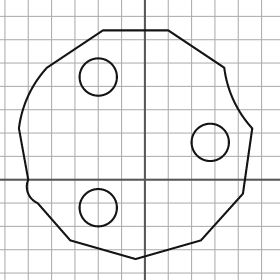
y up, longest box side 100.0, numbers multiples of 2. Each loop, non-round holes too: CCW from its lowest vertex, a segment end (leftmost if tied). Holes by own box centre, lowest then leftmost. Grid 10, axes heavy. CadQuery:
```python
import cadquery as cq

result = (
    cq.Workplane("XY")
    .moveTo(-4.0, -34.0)
    .lineTo(24.0, -26.0)
    .lineTo(42.0, -6.0)
    .lineTo(46.0, 22.0)
    .threePointArc((38.0, 34.0), (34.0, 48.0))
    .lineTo(10.0, 64.0)
    .lineTo(-18.0, 64.0)
    .lineTo(-42.0, 48.0)
    .threePointArc((-50.0, 36.0), (-54.0, 22.0))
    .lineTo(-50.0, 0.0)
    .threePointArc((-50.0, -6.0), (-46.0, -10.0))
    .lineTo(-32.0, -26.0)
    .close()
    .moveTo(-20.0, -12.0)
    .circle(8.0)
    .moveTo(28.0, 16.0)
    .circle(8.0)
    .moveTo(-20.0, 44.0)
    .circle(8.0)
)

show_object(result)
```